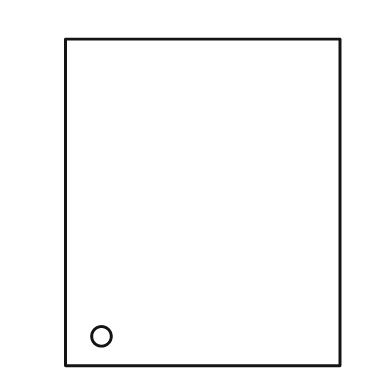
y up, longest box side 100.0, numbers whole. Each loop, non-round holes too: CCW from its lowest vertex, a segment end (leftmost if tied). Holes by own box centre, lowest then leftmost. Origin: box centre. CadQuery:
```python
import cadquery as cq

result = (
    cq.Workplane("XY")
    .moveTo(-42.0, -50.0)
    .lineTo(42.0, -50.0)
    .lineTo(42.0, 50.0)
    .lineTo(-42.0, 50.0)
    .close()
    .moveTo(-31.0, -41.0)
    .circle(3.0)
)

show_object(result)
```